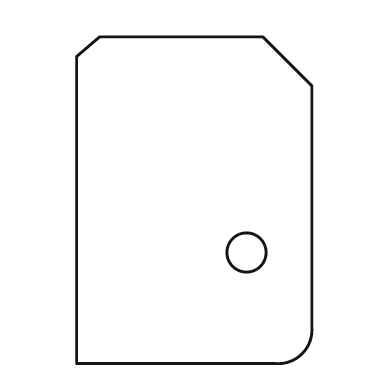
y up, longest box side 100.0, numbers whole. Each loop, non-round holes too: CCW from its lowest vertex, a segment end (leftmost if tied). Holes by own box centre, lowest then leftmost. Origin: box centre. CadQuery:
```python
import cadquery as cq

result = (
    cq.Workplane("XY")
    .moveTo(-36.0, -50.0)
    .lineTo(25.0, -50.0)
    .threePointArc((33.0, -47.0), (36.0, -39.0))
    .lineTo(36.0, 35.0)
    .lineTo(21.0, 50.0)
    .lineTo(-29.0, 50.0)
    .lineTo(-36.0, 44.0)
    .close()
    .moveTo(16.0, -16.0)
    .circle(6.0)
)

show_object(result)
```